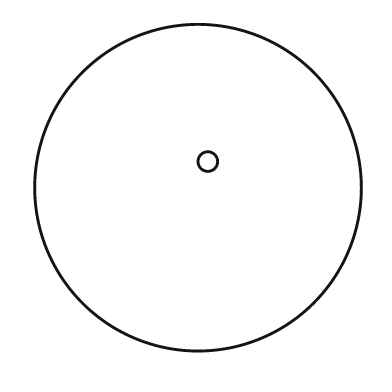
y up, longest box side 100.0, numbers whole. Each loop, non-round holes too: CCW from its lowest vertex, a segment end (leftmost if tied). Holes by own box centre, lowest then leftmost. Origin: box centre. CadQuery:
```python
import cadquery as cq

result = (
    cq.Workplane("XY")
    .moveTo(0.0, 0.0)
    .circle(50.0)
    .moveTo(3.0, 8.0)
    .circle(3.0)
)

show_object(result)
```